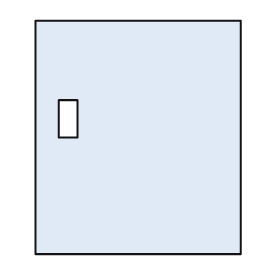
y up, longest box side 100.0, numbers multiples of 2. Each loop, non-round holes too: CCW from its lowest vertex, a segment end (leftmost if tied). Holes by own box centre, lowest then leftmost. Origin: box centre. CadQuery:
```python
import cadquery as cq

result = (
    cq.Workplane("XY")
    .moveTo(-44.0, -50.0)
    .lineTo(44.0, -50.0)
    .lineTo(44.0, 50.0)
    .lineTo(-44.0, 50.0)
    .close()
    .moveTo(-34.0, 0.0)
    .lineTo(-26.0, 0.0)
    .lineTo(-26.0, 16.0)
    .lineTo(-34.0, 16.0)
    .close()
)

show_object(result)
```